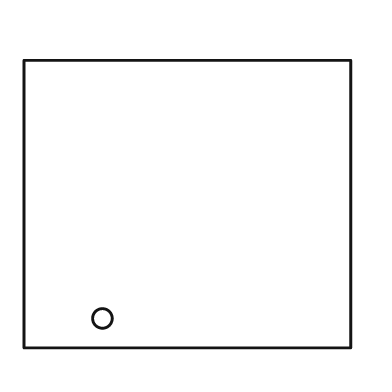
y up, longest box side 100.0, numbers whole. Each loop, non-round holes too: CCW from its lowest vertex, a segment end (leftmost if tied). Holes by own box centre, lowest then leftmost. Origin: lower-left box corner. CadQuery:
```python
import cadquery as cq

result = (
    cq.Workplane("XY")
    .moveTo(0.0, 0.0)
    .lineTo(100.0, 0.0)
    .lineTo(100.0, 88.0)
    .lineTo(0.0, 88.0)
    .close()
    .moveTo(24.0, 9.0)
    .circle(3.0)
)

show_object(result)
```